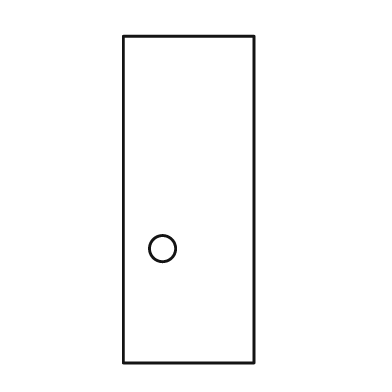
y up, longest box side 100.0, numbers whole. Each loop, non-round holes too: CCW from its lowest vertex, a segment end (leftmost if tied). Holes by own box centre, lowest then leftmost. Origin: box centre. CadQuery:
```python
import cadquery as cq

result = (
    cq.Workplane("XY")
    .moveTo(-20.0, -50.0)
    .lineTo(20.0, -50.0)
    .lineTo(20.0, 50.0)
    .lineTo(-20.0, 50.0)
    .close()
    .moveTo(-8.0, -15.0)
    .circle(4.0)
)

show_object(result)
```